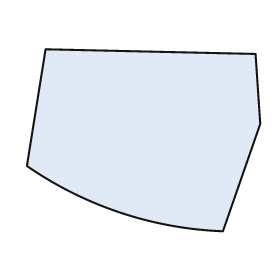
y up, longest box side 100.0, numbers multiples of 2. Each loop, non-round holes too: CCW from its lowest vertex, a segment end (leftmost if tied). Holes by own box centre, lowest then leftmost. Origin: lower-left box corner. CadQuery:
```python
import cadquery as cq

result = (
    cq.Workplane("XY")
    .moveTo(84.0, 0.0)
    .lineTo(100.0, 46.0)
    .lineTo(98.0, 76.0)
    .lineTo(8.0, 78.0)
    .lineTo(0.0, 28.0)
    .threePointArc((40.0, 8.0), (84.0, 0.0))
    .close()
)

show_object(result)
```